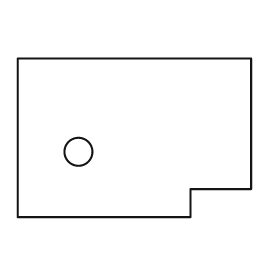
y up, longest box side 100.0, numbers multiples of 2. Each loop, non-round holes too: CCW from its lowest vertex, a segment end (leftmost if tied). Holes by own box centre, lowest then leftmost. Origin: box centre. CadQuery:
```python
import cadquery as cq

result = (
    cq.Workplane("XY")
    .moveTo(-50.0, -34.0)
    .lineTo(24.0, -34.0)
    .lineTo(24.0, -22.0)
    .lineTo(50.0, -22.0)
    .lineTo(50.0, 34.0)
    .lineTo(-50.0, 34.0)
    .close()
    .moveTo(-24.0, -6.0)
    .circle(6.0)
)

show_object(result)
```